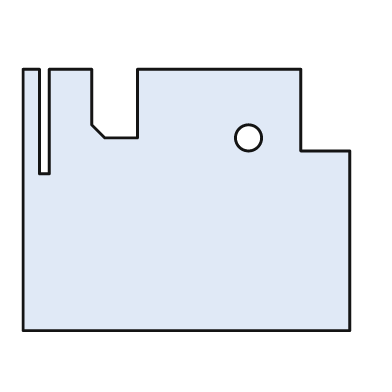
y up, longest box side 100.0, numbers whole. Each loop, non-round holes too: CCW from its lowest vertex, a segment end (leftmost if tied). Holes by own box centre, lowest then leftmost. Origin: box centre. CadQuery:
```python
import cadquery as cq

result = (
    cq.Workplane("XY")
    .moveTo(-50.0, -40.0)
    .lineTo(50.0, -40.0)
    .lineTo(50.0, 15.0)
    .lineTo(35.0, 15.0)
    .lineTo(35.0, 40.0)
    .lineTo(-15.0, 40.0)
    .lineTo(-15.0, 19.0)
    .lineTo(-25.0, 19.0)
    .lineTo(-29.0, 23.0)
    .lineTo(-29.0, 40.0)
    .lineTo(-42.0, 40.0)
    .lineTo(-42.0, 8.0)
    .lineTo(-45.0, 8.0)
    .lineTo(-45.0, 40.0)
    .lineTo(-50.0, 40.0)
    .close()
    .moveTo(19.0, 19.0)
    .circle(4.0)
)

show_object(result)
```